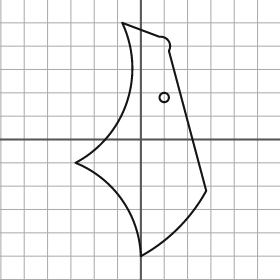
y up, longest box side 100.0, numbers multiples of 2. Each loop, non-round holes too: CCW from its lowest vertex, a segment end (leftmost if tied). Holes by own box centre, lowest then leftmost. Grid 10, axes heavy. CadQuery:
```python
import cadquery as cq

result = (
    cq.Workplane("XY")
    .moveTo(0.0, -50.0)
    .threePointArc((16.0, -38.0), (28.0, -22.0))
    .lineTo(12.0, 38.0)
    .threePointArc((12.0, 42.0), (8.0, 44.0))
    .lineTo(-8.0, 50.0)
    .threePointArc((-6.0, 16.0), (-28.0, -10.0))
    .threePointArc((-8.0, -26.0), (0.0, -50.0))
    .close()
    .moveTo(10.0, 18.0)
    .circle(2.0)
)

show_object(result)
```